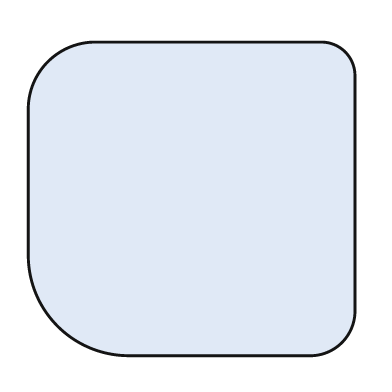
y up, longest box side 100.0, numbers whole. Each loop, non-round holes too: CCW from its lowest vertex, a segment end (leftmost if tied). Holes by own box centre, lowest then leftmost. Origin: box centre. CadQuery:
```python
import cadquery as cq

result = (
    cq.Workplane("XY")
    .moveTo(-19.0, -48.0)
    .lineTo(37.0, -48.0)
    .threePointArc((46.0, -44.0), (50.0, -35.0))
    .lineTo(50.0, 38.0)
    .threePointArc((47.0, 45.0), (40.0, 48.0))
    .lineTo(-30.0, 48.0)
    .threePointArc((-44.0, 42.0), (-50.0, 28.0))
    .lineTo(-50.0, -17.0)
    .threePointArc((-41.0, -39.0), (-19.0, -48.0))
    .close()
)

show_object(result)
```